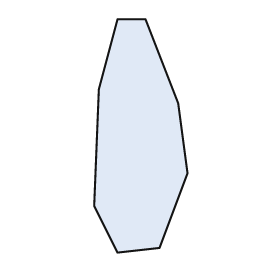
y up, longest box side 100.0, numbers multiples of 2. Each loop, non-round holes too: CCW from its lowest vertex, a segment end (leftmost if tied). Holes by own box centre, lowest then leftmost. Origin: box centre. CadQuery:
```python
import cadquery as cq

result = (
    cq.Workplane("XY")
    .moveTo(-10.0, -50.0)
    .lineTo(8.0, -48.0)
    .lineTo(20.0, -16.0)
    .lineTo(16.0, 14.0)
    .lineTo(2.0, 50.0)
    .lineTo(-10.0, 50.0)
    .lineTo(-18.0, 20.0)
    .lineTo(-20.0, -30.0)
    .close()
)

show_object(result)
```